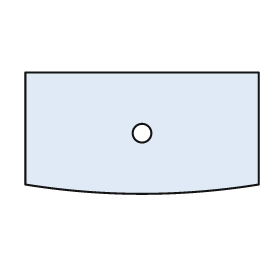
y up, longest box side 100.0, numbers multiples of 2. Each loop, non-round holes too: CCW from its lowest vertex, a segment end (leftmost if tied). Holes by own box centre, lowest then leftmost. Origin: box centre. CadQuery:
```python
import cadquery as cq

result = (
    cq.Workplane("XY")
    .moveTo(-50.0, -22.0)
    .threePointArc((0.0, -26.0), (50.0, -22.0))
    .lineTo(50.0, 26.0)
    .lineTo(-50.0, 26.0)
    .close()
    .moveTo(0.0, 0.0)
    .circle(4.0)
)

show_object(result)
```